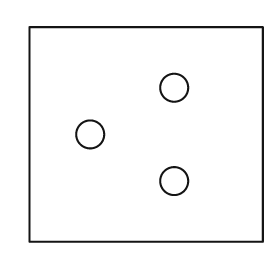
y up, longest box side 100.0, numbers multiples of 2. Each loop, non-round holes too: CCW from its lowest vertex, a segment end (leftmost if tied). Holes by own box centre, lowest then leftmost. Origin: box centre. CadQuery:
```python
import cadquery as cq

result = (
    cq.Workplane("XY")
    .moveTo(-50.0, -46.0)
    .lineTo(50.0, -46.0)
    .lineTo(50.0, 46.0)
    .lineTo(-50.0, 46.0)
    .close()
    .moveTo(12.0, -20.0)
    .circle(6.0)
    .moveTo(-24.0, 0.0)
    .circle(6.0)
    .moveTo(12.0, 20.0)
    .circle(6.0)
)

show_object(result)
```